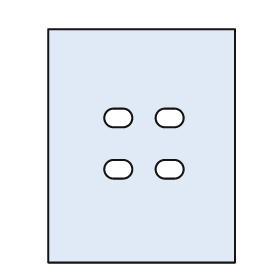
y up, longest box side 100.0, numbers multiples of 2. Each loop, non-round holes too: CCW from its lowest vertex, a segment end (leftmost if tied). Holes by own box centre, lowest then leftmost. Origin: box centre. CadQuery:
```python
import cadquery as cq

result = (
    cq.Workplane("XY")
    .moveTo(-40.0, -50.0)
    .lineTo(40.0, -50.0)
    .lineTo(40.0, 50.0)
    .lineTo(-40.0, 50.0)
    .close()
    .moveTo(-12.0, -14.0)
    .lineTo(-8.0, -14.0)
    .threePointArc((-4.0, -10.0), (-8.0, -6.0))
    .lineTo(-12.0, -6.0)
    .threePointArc((-16.0, -10.0), (-12.0, -14.0))
    .close()
    .moveTo(10.0, -14.0)
    .lineTo(14.0, -14.0)
    .threePointArc((18.0, -10.0), (14.0, -6.0))
    .lineTo(10.0, -6.0)
    .threePointArc((6.0, -10.0), (10.0, -14.0))
    .close()
    .moveTo(-12.0, 8.0)
    .lineTo(-8.0, 8.0)
    .threePointArc((-4.0, 12.0), (-8.0, 16.0))
    .lineTo(-12.0, 16.0)
    .threePointArc((-16.0, 12.0), (-12.0, 8.0))
    .close()
    .moveTo(10.0, 8.0)
    .lineTo(14.0, 8.0)
    .threePointArc((18.0, 12.0), (14.0, 16.0))
    .lineTo(10.0, 16.0)
    .threePointArc((6.0, 12.0), (10.0, 8.0))
    .close()
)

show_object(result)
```